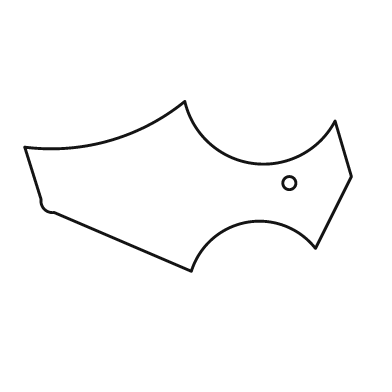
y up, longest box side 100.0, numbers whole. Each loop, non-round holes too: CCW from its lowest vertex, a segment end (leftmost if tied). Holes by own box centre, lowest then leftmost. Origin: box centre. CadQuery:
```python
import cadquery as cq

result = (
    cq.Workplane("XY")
    .moveTo(1.0, -26.0)
    .threePointArc((18.0, -11.0), (39.0, -19.0))
    .lineTo(50.0, 3.0)
    .lineTo(45.0, 20.0)
    .threePointArc((20.0, 7.0), (-1.0, 26.0))
    .threePointArc((-24.0, 14.0), (-50.0, 12.0))
    .lineTo(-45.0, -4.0)
    .threePointArc((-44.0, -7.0), (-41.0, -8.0))
    .close()
    .moveTo(31.0, 1.0)
    .circle(2.0)
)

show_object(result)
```